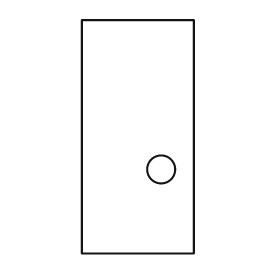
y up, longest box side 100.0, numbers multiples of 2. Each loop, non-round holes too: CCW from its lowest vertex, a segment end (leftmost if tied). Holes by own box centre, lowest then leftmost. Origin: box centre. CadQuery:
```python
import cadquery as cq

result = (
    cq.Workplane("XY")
    .moveTo(-24.0, -50.0)
    .lineTo(24.0, -50.0)
    .lineTo(24.0, 50.0)
    .lineTo(-24.0, 50.0)
    .close()
    .moveTo(10.0, -14.0)
    .circle(6.0)
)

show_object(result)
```